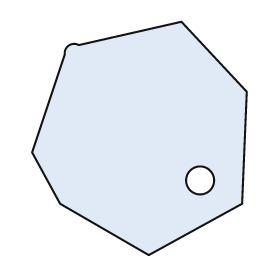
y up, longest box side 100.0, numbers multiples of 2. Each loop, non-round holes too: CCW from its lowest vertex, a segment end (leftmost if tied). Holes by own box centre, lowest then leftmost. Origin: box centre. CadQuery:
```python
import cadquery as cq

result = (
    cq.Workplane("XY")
    .moveTo(4.0, -50.0)
    .lineTo(44.0, -28.0)
    .lineTo(46.0, 20.0)
    .lineTo(18.0, 50.0)
    .lineTo(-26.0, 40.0)
    .threePointArc((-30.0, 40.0), (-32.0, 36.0))
    .lineTo(-46.0, -6.0)
    .lineTo(-34.0, -28.0)
    .close()
    .moveTo(26.0, -18.0)
    .circle(6.0)
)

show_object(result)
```